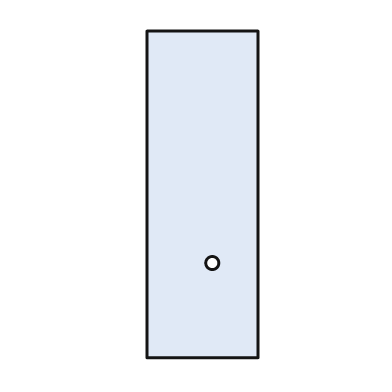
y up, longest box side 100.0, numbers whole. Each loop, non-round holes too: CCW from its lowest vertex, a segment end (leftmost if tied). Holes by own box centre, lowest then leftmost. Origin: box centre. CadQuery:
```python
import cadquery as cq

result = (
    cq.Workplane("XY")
    .moveTo(-17.0, -50.0)
    .lineTo(17.0, -50.0)
    .lineTo(17.0, 50.0)
    .lineTo(-17.0, 50.0)
    .close()
    .moveTo(3.0, -21.0)
    .circle(2.0)
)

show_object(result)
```